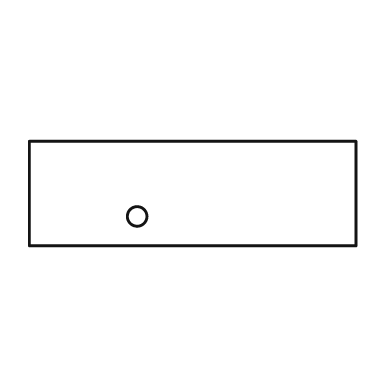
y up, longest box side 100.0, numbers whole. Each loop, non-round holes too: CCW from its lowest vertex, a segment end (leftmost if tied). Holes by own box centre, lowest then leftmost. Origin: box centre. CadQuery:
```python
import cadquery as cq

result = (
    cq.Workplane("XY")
    .moveTo(-50.0, -16.0)
    .lineTo(50.0, -16.0)
    .lineTo(50.0, 16.0)
    .lineTo(-50.0, 16.0)
    .close()
    .moveTo(-17.0, -7.0)
    .circle(3.0)
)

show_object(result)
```